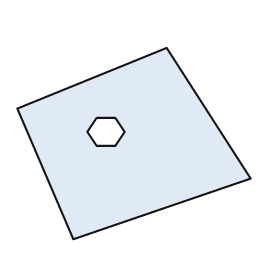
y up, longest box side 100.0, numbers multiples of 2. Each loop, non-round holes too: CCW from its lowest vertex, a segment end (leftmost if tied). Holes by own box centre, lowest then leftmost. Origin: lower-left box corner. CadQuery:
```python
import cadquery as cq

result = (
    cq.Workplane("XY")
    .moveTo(24.0, 0.0)
    .lineTo(100.0, 26.0)
    .lineTo(64.0, 82.0)
    .lineTo(0.0, 56.0)
    .close()
    .moveTo(34.0, 40.0)
    .lineTo(42.0, 40.0)
    .lineTo(46.0, 46.0)
    .lineTo(42.0, 52.0)
    .lineTo(34.0, 52.0)
    .lineTo(30.0, 46.0)
    .close()
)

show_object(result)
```